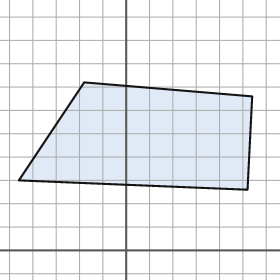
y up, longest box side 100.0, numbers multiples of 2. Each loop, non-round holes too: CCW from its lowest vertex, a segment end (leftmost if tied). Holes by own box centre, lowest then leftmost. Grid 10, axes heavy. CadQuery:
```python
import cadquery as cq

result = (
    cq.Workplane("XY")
    .moveTo(52.0, 26.0)
    .lineTo(54.0, 66.0)
    .lineTo(-18.0, 72.0)
    .lineTo(-46.0, 30.0)
    .close()
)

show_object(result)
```